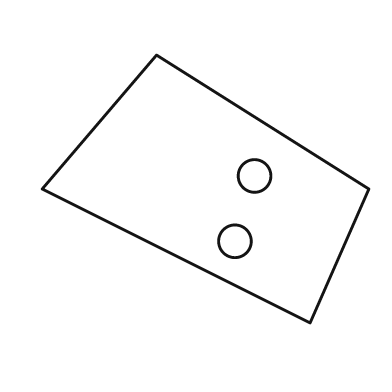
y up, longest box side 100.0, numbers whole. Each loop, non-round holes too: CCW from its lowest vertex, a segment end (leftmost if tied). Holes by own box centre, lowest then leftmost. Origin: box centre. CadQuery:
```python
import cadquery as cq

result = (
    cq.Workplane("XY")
    .moveTo(32.0, -41.0)
    .lineTo(50.0, 0.0)
    .lineTo(-15.0, 41.0)
    .lineTo(-50.0, 0.0)
    .close()
    .moveTo(9.0, -16.0)
    .circle(5.0)
    .moveTo(15.0, 4.0)
    .circle(5.0)
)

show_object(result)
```